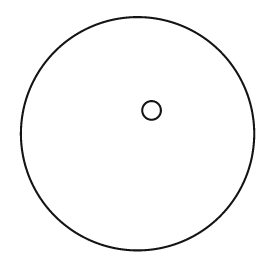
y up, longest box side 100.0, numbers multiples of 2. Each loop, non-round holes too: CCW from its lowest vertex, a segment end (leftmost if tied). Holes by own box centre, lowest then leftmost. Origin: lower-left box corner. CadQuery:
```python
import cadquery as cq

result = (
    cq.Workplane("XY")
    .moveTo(50.0, 50.0)
    .circle(50.0)
    .moveTo(56.0, 60.0)
    .circle(4.0)
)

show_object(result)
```